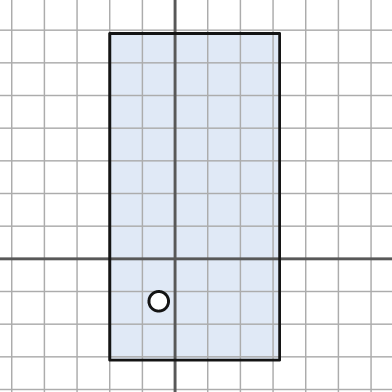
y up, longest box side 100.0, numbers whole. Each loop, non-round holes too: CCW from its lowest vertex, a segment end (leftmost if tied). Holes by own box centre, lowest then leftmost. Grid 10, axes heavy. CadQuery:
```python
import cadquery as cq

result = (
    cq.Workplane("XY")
    .moveTo(-20.0, -31.0)
    .lineTo(32.0, -31.0)
    .lineTo(32.0, 69.0)
    .lineTo(-20.0, 69.0)
    .close()
    .moveTo(-5.0, -13.0)
    .circle(3.0)
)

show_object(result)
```